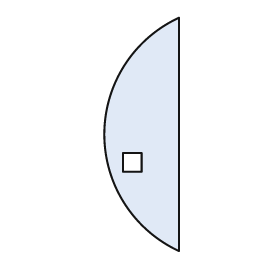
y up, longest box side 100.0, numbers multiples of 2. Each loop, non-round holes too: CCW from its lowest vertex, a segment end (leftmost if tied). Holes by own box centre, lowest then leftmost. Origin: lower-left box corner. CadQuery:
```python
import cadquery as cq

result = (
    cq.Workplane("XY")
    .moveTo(32.0, 0.0)
    .lineTo(32.0, 100.0)
    .threePointArc((0.0, 50.0), (32.0, 0.0))
    .close()
    .moveTo(8.0, 34.0)
    .lineTo(16.0, 34.0)
    .lineTo(16.0, 42.0)
    .lineTo(8.0, 42.0)
    .close()
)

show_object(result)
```